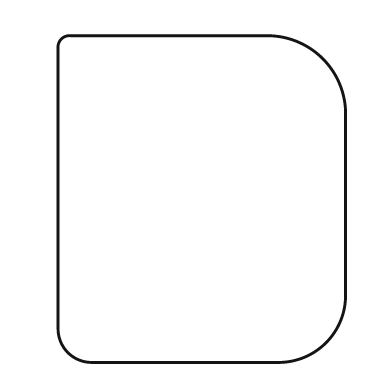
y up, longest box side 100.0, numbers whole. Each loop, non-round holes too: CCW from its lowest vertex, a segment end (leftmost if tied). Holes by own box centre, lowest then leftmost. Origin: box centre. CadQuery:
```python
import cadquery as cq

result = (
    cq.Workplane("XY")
    .moveTo(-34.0, -50.0)
    .lineTo(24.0, -50.0)
    .threePointArc((38.0, -44.0), (44.0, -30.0))
    .lineTo(44.0, 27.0)
    .threePointArc((37.0, 43.0), (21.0, 50.0))
    .lineTo(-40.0, 50.0)
    .threePointArc((-43.0, 49.0), (-44.0, 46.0))
    .lineTo(-44.0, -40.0)
    .threePointArc((-41.0, -47.0), (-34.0, -50.0))
    .close()
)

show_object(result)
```